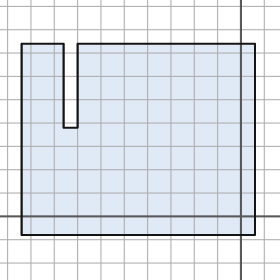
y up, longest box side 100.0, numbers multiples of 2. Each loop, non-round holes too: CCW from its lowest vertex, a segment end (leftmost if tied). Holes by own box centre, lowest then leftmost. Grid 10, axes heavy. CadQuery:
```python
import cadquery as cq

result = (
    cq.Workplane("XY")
    .moveTo(-94.0, -8.0)
    .lineTo(6.0, -8.0)
    .lineTo(6.0, 74.0)
    .lineTo(-70.0, 74.0)
    .lineTo(-70.0, 38.0)
    .lineTo(-76.0, 38.0)
    .lineTo(-76.0, 74.0)
    .lineTo(-94.0, 74.0)
    .close()
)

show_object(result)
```